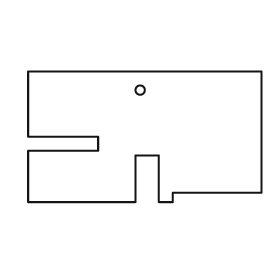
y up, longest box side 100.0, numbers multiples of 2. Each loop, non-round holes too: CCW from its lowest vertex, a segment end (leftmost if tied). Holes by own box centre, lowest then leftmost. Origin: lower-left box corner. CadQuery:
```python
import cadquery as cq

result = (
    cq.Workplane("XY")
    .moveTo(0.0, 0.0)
    .lineTo(46.0, 0.0)
    .lineTo(46.0, 20.0)
    .lineTo(56.0, 20.0)
    .lineTo(56.0, 0.0)
    .lineTo(62.0, 0.0)
    .lineTo(62.0, 4.0)
    .lineTo(100.0, 4.0)
    .lineTo(100.0, 56.0)
    .lineTo(0.0, 56.0)
    .lineTo(0.0, 28.0)
    .lineTo(30.0, 28.0)
    .lineTo(30.0, 22.0)
    .lineTo(0.0, 22.0)
    .close()
    .moveTo(48.0, 48.0)
    .circle(2.0)
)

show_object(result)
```